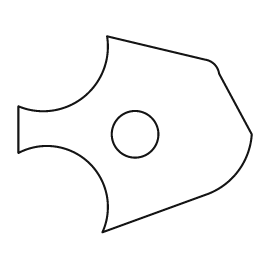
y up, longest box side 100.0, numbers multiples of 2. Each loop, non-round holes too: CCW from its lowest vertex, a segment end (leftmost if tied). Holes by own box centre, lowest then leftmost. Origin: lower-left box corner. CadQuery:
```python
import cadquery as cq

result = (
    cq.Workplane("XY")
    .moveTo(36.0, 0.0)
    .lineTo(80.0, 16.0)
    .threePointArc((94.0, 26.0), (100.0, 42.0))
    .lineTo(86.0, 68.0)
    .threePointArc((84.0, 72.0), (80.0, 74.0))
    .lineTo(38.0, 84.0)
    .threePointArc((28.0, 58.0), (0.0, 54.0))
    .lineTo(0.0, 34.0)
    .threePointArc((30.0, 30.0), (36.0, 0.0))
    .close()
    .moveTo(50.0, 42.0)
    .circle(10.0)
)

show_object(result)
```